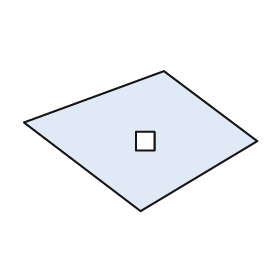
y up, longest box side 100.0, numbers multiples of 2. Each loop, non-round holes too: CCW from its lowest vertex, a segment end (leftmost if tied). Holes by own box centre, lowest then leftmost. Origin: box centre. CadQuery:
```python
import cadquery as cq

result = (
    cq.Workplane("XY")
    .moveTo(0.0, -30.0)
    .lineTo(50.0, 0.0)
    .lineTo(10.0, 30.0)
    .lineTo(-50.0, 8.0)
    .close()
    .moveTo(-2.0, -4.0)
    .lineTo(6.0, -4.0)
    .lineTo(6.0, 4.0)
    .lineTo(-2.0, 4.0)
    .close()
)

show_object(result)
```